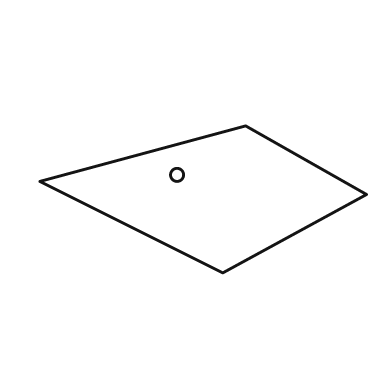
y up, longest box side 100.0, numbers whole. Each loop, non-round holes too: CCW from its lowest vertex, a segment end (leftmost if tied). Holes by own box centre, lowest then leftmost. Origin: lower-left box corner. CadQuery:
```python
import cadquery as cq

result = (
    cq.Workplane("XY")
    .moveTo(56.0, 0.0)
    .lineTo(100.0, 24.0)
    .lineTo(63.0, 45.0)
    .lineTo(0.0, 28.0)
    .close()
    .moveTo(42.0, 30.0)
    .circle(2.0)
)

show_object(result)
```